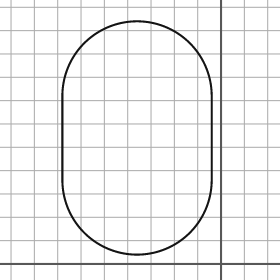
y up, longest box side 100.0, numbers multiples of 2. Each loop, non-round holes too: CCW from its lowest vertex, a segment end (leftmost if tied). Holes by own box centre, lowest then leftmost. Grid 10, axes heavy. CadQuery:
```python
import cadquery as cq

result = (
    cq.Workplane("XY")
    .moveTo(-68.0, 36.0)
    .threePointArc((-36.0, 4.0), (-4.0, 36.0))
    .lineTo(-4.0, 72.0)
    .threePointArc((-36.0, 104.0), (-68.0, 72.0))
    .close()
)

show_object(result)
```